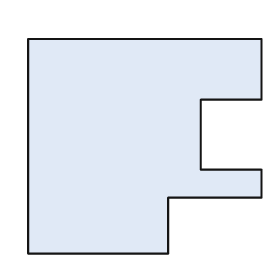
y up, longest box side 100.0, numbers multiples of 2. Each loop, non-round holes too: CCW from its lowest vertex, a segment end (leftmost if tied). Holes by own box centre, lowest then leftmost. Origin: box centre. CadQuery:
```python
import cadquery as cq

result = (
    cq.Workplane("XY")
    .moveTo(-50.0, -46.0)
    .lineTo(10.0, -46.0)
    .lineTo(10.0, -22.0)
    .lineTo(50.0, -22.0)
    .lineTo(50.0, -10.0)
    .lineTo(24.0, -10.0)
    .lineTo(24.0, 20.0)
    .lineTo(50.0, 20.0)
    .lineTo(50.0, 46.0)
    .lineTo(-50.0, 46.0)
    .close()
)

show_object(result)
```